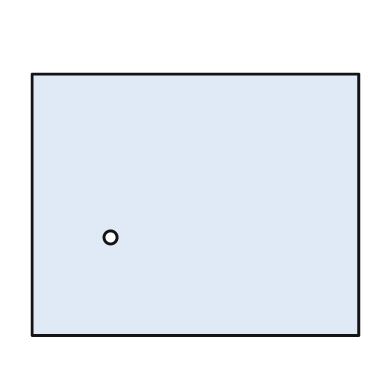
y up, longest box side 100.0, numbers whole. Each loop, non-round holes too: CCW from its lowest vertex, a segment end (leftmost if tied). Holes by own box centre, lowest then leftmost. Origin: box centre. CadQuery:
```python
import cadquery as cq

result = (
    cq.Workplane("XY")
    .moveTo(-50.0, -40.0)
    .lineTo(50.0, -40.0)
    .lineTo(50.0, 40.0)
    .lineTo(-50.0, 40.0)
    .close()
    .moveTo(-26.0, -10.0)
    .circle(2.0)
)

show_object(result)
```